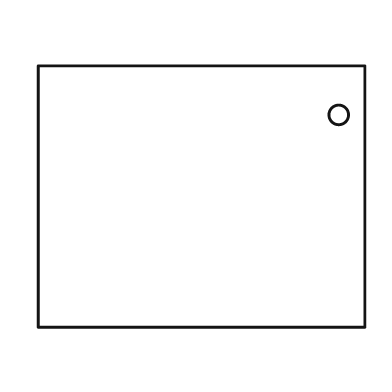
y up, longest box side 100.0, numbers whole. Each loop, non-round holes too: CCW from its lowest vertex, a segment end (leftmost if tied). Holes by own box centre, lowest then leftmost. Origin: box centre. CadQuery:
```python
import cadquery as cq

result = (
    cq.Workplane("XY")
    .moveTo(-50.0, -40.0)
    .lineTo(50.0, -40.0)
    .lineTo(50.0, 40.0)
    .lineTo(-50.0, 40.0)
    .close()
    .moveTo(42.0, 25.0)
    .circle(3.0)
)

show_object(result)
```